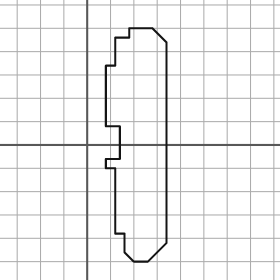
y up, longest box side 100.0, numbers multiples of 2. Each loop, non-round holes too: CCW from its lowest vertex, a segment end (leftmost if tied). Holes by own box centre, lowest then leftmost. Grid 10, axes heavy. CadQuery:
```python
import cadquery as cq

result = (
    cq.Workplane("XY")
    .moveTo(20.0, -50.0)
    .lineTo(26.0, -50.0)
    .lineTo(34.0, -42.0)
    .lineTo(34.0, 44.0)
    .lineTo(28.0, 50.0)
    .lineTo(18.0, 50.0)
    .lineTo(18.0, 46.0)
    .lineTo(12.0, 46.0)
    .lineTo(12.0, 34.0)
    .lineTo(8.0, 34.0)
    .lineTo(8.0, 8.0)
    .lineTo(14.0, 8.0)
    .lineTo(14.0, -6.0)
    .lineTo(8.0, -6.0)
    .lineTo(8.0, -10.0)
    .lineTo(12.0, -10.0)
    .lineTo(12.0, -38.0)
    .lineTo(16.0, -38.0)
    .lineTo(16.0, -46.0)
    .close()
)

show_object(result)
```